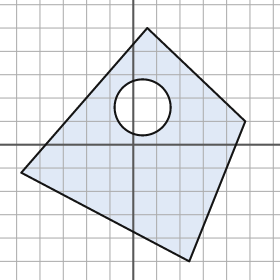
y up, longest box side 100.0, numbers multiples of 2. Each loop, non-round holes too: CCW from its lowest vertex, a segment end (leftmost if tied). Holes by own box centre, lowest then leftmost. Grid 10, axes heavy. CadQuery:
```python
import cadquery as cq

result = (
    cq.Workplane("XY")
    .moveTo(24.0, -50.0)
    .lineTo(48.0, 10.0)
    .lineTo(6.0, 50.0)
    .lineTo(-48.0, -12.0)
    .close()
    .moveTo(4.0, 16.0)
    .circle(12.0)
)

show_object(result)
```